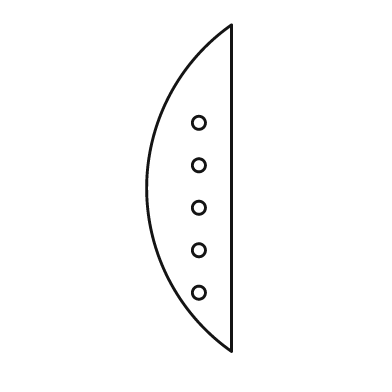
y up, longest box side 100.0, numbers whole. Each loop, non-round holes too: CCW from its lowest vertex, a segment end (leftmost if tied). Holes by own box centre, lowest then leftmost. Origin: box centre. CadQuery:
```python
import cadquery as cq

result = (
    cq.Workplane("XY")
    .moveTo(13.0, -50.0)
    .lineTo(13.0, 50.0)
    .threePointArc((-13.0, 0.0), (13.0, -50.0))
    .close()
    .moveTo(3.0, -32.0)
    .circle(2.0)
    .moveTo(3.0, -19.0)
    .circle(2.0)
    .moveTo(3.0, -6.0)
    .circle(2.0)
    .moveTo(3.0, 7.0)
    .circle(2.0)
    .moveTo(3.0, 20.0)
    .circle(2.0)
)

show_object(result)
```